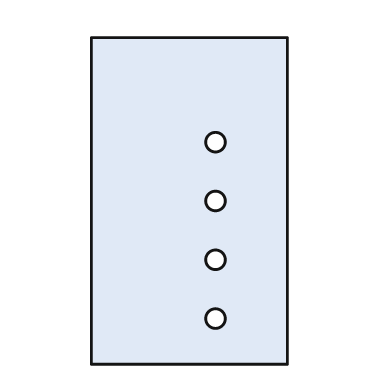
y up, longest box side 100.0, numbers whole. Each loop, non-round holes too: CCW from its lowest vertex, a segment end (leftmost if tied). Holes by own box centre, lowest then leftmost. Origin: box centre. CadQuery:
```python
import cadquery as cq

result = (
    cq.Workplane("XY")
    .moveTo(-30.0, -50.0)
    .lineTo(30.0, -50.0)
    .lineTo(30.0, 50.0)
    .lineTo(-30.0, 50.0)
    .close()
    .moveTo(8.0, -36.0)
    .circle(3.0)
    .moveTo(8.0, -18.0)
    .circle(3.0)
    .moveTo(8.0, 0.0)
    .circle(3.0)
    .moveTo(8.0, 18.0)
    .circle(3.0)
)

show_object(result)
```